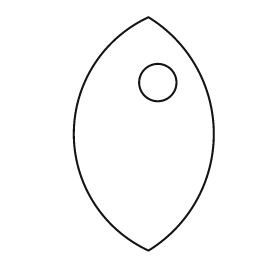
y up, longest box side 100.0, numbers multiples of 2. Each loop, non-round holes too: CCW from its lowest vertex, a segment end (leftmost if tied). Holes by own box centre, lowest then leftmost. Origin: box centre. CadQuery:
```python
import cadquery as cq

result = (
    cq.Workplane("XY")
    .moveTo(2.0, -50.0)
    .threePointArc((30.0, 0.0), (2.0, 50.0))
    .threePointArc((-30.0, 0.0), (2.0, -50.0))
    .close()
    .moveTo(6.0, 22.0)
    .circle(8.0)
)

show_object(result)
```